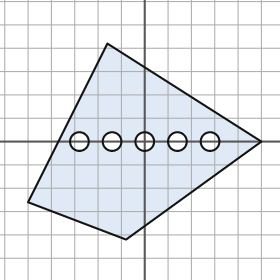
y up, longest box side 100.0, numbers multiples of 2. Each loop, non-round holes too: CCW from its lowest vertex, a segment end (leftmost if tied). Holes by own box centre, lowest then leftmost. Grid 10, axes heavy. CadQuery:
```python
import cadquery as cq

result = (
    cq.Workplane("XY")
    .moveTo(-8.0, -42.0)
    .lineTo(50.0, 0.0)
    .lineTo(-16.0, 42.0)
    .lineTo(-50.0, -26.0)
    .close()
    .moveTo(-28.0, 0.0)
    .circle(4.0)
    .moveTo(-14.0, 0.0)
    .circle(4.0)
    .moveTo(0.0, 0.0)
    .circle(4.0)
    .moveTo(14.0, 0.0)
    .circle(4.0)
    .moveTo(28.0, 0.0)
    .circle(4.0)
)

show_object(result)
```